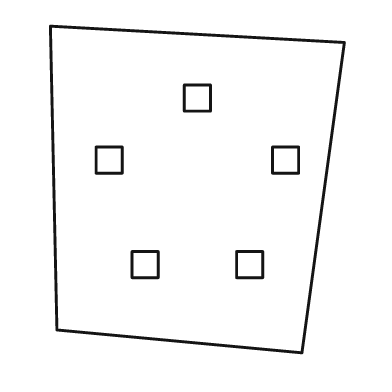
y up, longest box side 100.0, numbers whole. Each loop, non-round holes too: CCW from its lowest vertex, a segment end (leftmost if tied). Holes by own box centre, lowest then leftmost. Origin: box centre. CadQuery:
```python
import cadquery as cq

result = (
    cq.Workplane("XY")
    .moveTo(32.0, -50.0)
    .lineTo(45.0, 45.0)
    .lineTo(-45.0, 50.0)
    .lineTo(-43.0, -43.0)
    .close()
    .moveTo(-20.0, -27.0)
    .lineTo(-12.0, -27.0)
    .lineTo(-12.0, -19.0)
    .lineTo(-20.0, -19.0)
    .close()
    .moveTo(12.0, -27.0)
    .lineTo(20.0, -27.0)
    .lineTo(20.0, -19.0)
    .lineTo(12.0, -19.0)
    .close()
    .moveTo(-31.0, 5.0)
    .lineTo(-23.0, 5.0)
    .lineTo(-23.0, 13.0)
    .lineTo(-31.0, 13.0)
    .close()
    .moveTo(23.0, 5.0)
    .lineTo(31.0, 5.0)
    .lineTo(31.0, 13.0)
    .lineTo(23.0, 13.0)
    .close()
    .moveTo(-4.0, 24.0)
    .lineTo(4.0, 24.0)
    .lineTo(4.0, 32.0)
    .lineTo(-4.0, 32.0)
    .close()
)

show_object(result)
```